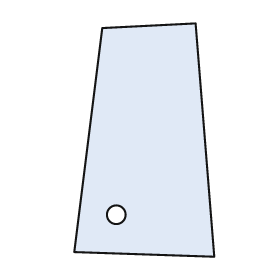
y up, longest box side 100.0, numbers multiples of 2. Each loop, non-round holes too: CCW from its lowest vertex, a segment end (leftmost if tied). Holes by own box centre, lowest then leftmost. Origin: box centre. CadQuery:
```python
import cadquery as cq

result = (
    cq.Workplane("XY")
    .moveTo(30.0, -50.0)
    .lineTo(22.0, 50.0)
    .lineTo(-18.0, 48.0)
    .lineTo(-30.0, -48.0)
    .close()
    .moveTo(-12.0, -32.0)
    .circle(4.0)
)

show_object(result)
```